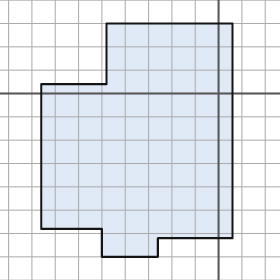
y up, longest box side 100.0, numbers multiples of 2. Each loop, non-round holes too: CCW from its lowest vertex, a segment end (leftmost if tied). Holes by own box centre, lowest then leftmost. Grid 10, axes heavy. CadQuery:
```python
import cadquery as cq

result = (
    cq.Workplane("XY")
    .moveTo(-50.0, -70.0)
    .lineTo(-26.0, -70.0)
    .lineTo(-26.0, -62.0)
    .lineTo(6.0, -62.0)
    .lineTo(6.0, 30.0)
    .lineTo(-48.0, 30.0)
    .lineTo(-48.0, 4.0)
    .lineTo(-76.0, 4.0)
    .lineTo(-76.0, -58.0)
    .lineTo(-50.0, -58.0)
    .close()
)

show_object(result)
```